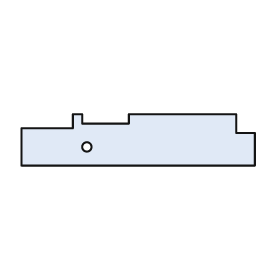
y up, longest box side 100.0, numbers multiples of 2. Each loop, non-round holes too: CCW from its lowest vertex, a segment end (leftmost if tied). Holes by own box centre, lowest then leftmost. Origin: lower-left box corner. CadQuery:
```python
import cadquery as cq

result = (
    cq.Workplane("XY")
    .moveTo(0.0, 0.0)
    .lineTo(100.0, 0.0)
    .lineTo(100.0, 14.0)
    .lineTo(92.0, 14.0)
    .lineTo(92.0, 22.0)
    .lineTo(46.0, 22.0)
    .lineTo(46.0, 18.0)
    .lineTo(26.0, 18.0)
    .lineTo(26.0, 22.0)
    .lineTo(22.0, 22.0)
    .lineTo(22.0, 16.0)
    .lineTo(0.0, 16.0)
    .close()
    .moveTo(28.0, 8.0)
    .circle(2.0)
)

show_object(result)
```